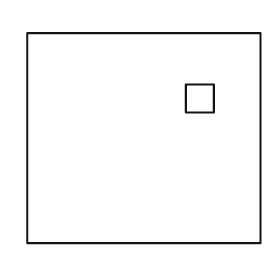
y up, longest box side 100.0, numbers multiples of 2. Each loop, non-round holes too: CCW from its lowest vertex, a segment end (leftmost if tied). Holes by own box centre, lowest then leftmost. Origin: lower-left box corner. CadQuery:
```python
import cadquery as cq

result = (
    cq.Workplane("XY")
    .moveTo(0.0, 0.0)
    .lineTo(100.0, 0.0)
    .lineTo(100.0, 90.0)
    .lineTo(0.0, 90.0)
    .close()
    .moveTo(68.0, 56.0)
    .lineTo(80.0, 56.0)
    .lineTo(80.0, 68.0)
    .lineTo(68.0, 68.0)
    .close()
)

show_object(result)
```